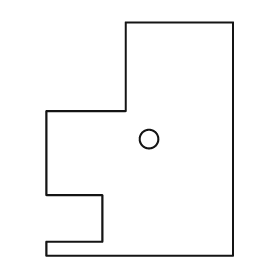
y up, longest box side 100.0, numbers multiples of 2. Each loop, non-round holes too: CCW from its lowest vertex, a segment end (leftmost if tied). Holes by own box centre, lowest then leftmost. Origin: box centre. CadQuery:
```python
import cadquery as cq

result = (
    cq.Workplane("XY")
    .moveTo(-40.0, -50.0)
    .lineTo(40.0, -50.0)
    .lineTo(40.0, 50.0)
    .lineTo(-6.0, 50.0)
    .lineTo(-6.0, 12.0)
    .lineTo(-40.0, 12.0)
    .lineTo(-40.0, -24.0)
    .lineTo(-16.0, -24.0)
    .lineTo(-16.0, -44.0)
    .lineTo(-40.0, -44.0)
    .close()
    .moveTo(4.0, 0.0)
    .circle(4.0)
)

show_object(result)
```